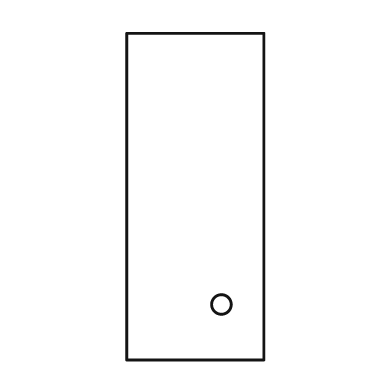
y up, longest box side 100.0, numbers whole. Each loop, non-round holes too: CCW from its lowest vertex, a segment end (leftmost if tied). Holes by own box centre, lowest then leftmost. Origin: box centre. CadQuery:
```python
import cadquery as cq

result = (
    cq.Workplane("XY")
    .moveTo(-21.0, -50.0)
    .lineTo(21.0, -50.0)
    .lineTo(21.0, 50.0)
    .lineTo(-21.0, 50.0)
    .close()
    .moveTo(8.0, -33.0)
    .circle(3.0)
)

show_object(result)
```